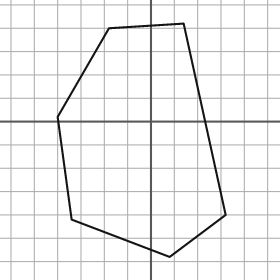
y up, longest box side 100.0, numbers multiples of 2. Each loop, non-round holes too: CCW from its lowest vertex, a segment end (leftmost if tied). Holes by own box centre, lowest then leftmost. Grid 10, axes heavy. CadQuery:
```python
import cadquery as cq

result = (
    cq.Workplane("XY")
    .moveTo(8.0, -58.0)
    .lineTo(32.0, -40.0)
    .lineTo(14.0, 42.0)
    .lineTo(-18.0, 40.0)
    .lineTo(-40.0, 2.0)
    .lineTo(-34.0, -42.0)
    .close()
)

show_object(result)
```